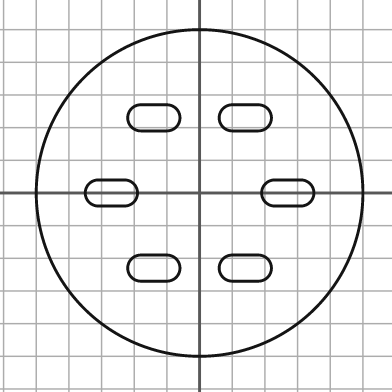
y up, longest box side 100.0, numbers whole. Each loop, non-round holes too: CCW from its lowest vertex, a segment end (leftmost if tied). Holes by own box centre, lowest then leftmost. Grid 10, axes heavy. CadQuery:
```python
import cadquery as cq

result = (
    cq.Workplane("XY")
    .moveTo(0.0, 0.0)
    .circle(50.0)
    .moveTo(-18.0, -27.0)
    .lineTo(-10.0, -27.0)
    .threePointArc((-6.0, -23.0), (-10.0, -19.0))
    .lineTo(-18.0, -19.0)
    .threePointArc((-22.0, -23.0), (-18.0, -27.0))
    .close()
    .moveTo(10.0, -27.0)
    .lineTo(18.0, -27.0)
    .threePointArc((22.0, -23.0), (18.0, -19.0))
    .lineTo(10.0, -19.0)
    .threePointArc((6.0, -23.0), (10.0, -27.0))
    .close()
    .moveTo(-31.0, -4.0)
    .lineTo(-23.0, -4.0)
    .threePointArc((-19.0, 0.0), (-23.0, 4.0))
    .lineTo(-31.0, 4.0)
    .threePointArc((-35.0, 0.0), (-31.0, -4.0))
    .close()
    .moveTo(23.0, -4.0)
    .lineTo(31.0, -4.0)
    .threePointArc((35.0, 0.0), (31.0, 4.0))
    .lineTo(23.0, 4.0)
    .threePointArc((19.0, 0.0), (23.0, -4.0))
    .close()
    .moveTo(-18.0, 19.0)
    .lineTo(-10.0, 19.0)
    .threePointArc((-6.0, 23.0), (-10.0, 27.0))
    .lineTo(-18.0, 27.0)
    .threePointArc((-22.0, 23.0), (-18.0, 19.0))
    .close()
    .moveTo(10.0, 19.0)
    .lineTo(18.0, 19.0)
    .threePointArc((22.0, 23.0), (18.0, 27.0))
    .lineTo(10.0, 27.0)
    .threePointArc((6.0, 23.0), (10.0, 19.0))
    .close()
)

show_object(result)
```